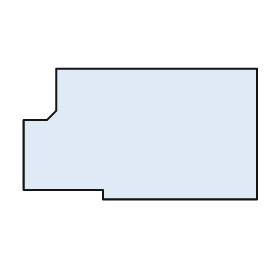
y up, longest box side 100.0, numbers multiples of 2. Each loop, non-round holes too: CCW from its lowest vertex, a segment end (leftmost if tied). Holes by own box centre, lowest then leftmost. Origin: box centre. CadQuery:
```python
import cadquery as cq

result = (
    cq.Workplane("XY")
    .moveTo(-16.0, -28.0)
    .lineTo(50.0, -28.0)
    .lineTo(50.0, 28.0)
    .lineTo(-36.0, 28.0)
    .lineTo(-36.0, 10.0)
    .lineTo(-40.0, 6.0)
    .lineTo(-50.0, 6.0)
    .lineTo(-50.0, -24.0)
    .lineTo(-16.0, -24.0)
    .close()
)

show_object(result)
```